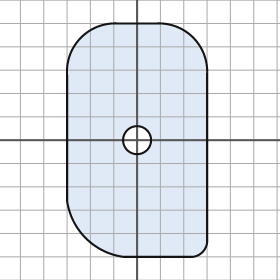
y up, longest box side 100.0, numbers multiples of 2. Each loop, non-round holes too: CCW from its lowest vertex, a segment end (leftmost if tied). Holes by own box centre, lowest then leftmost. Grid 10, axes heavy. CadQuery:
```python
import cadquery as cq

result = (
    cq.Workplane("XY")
    .moveTo(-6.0, -50.0)
    .lineTo(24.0, -50.0)
    .threePointArc((28.0, -48.0), (30.0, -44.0))
    .lineTo(30.0, 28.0)
    .threePointArc((24.0, 44.0), (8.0, 50.0))
    .lineTo(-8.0, 50.0)
    .threePointArc((-24.0, 44.0), (-30.0, 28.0))
    .lineTo(-30.0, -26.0)
    .threePointArc((-22.0, -42.0), (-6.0, -50.0))
    .close()
    .moveTo(0.0, 0.0)
    .circle(6.0)
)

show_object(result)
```